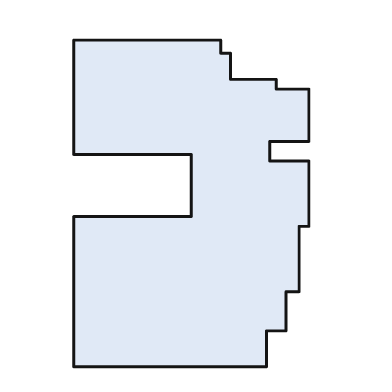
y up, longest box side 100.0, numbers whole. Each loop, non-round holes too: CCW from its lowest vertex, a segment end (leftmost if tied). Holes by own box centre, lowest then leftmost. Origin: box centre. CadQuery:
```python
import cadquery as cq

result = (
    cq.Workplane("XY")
    .moveTo(-36.0, -50.0)
    .lineTo(23.0, -50.0)
    .lineTo(23.0, -39.0)
    .lineTo(29.0, -39.0)
    .lineTo(29.0, -27.0)
    .lineTo(33.0, -27.0)
    .lineTo(33.0, -7.0)
    .lineTo(36.0, -7.0)
    .lineTo(36.0, 13.0)
    .lineTo(24.0, 13.0)
    .lineTo(24.0, 19.0)
    .lineTo(36.0, 19.0)
    .lineTo(36.0, 35.0)
    .lineTo(26.0, 35.0)
    .lineTo(26.0, 38.0)
    .lineTo(12.0, 38.0)
    .lineTo(12.0, 46.0)
    .lineTo(9.0, 46.0)
    .lineTo(9.0, 50.0)
    .lineTo(-36.0, 50.0)
    .lineTo(-36.0, 15.0)
    .lineTo(0.0, 15.0)
    .lineTo(0.0, -4.0)
    .lineTo(-36.0, -4.0)
    .close()
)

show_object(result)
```